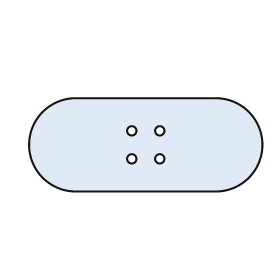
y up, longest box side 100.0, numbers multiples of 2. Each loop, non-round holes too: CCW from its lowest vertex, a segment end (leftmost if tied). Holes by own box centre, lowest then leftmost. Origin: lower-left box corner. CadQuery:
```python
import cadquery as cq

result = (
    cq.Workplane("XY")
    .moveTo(20.0, 0.0)
    .lineTo(80.0, 0.0)
    .threePointArc((100.0, 20.0), (80.0, 40.0))
    .lineTo(20.0, 40.0)
    .threePointArc((0.0, 20.0), (20.0, 0.0))
    .close()
    .moveTo(44.0, 14.0)
    .circle(2.0)
    .moveTo(56.0, 14.0)
    .circle(2.0)
    .moveTo(44.0, 26.0)
    .circle(2.0)
    .moveTo(56.0, 26.0)
    .circle(2.0)
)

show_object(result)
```